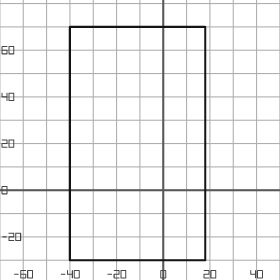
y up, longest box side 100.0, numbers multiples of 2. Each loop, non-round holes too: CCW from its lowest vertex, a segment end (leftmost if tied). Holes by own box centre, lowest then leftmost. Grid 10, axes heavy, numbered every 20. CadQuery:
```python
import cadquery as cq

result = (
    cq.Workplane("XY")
    .moveTo(-40.0, -30.0)
    .lineTo(18.0, -30.0)
    .lineTo(18.0, 70.0)
    .lineTo(-40.0, 70.0)
    .close()
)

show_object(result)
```